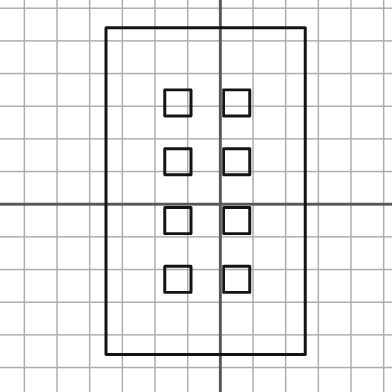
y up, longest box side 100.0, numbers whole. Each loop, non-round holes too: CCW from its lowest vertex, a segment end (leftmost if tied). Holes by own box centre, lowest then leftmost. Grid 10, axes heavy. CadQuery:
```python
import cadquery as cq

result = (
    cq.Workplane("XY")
    .moveTo(-35.0, -46.0)
    .lineTo(26.0, -46.0)
    .lineTo(26.0, 54.0)
    .lineTo(-35.0, 54.0)
    .close()
    .moveTo(-17.0, -27.0)
    .lineTo(-9.0, -27.0)
    .lineTo(-9.0, -19.0)
    .lineTo(-17.0, -19.0)
    .close()
    .moveTo(1.0, -27.0)
    .lineTo(9.0, -27.0)
    .lineTo(9.0, -19.0)
    .lineTo(1.0, -19.0)
    .close()
    .moveTo(-17.0, -9.0)
    .lineTo(-9.0, -9.0)
    .lineTo(-9.0, -1.0)
    .lineTo(-17.0, -1.0)
    .close()
    .moveTo(1.0, -9.0)
    .lineTo(9.0, -9.0)
    .lineTo(9.0, -1.0)
    .lineTo(1.0, -1.0)
    .close()
    .moveTo(-17.0, 9.0)
    .lineTo(-9.0, 9.0)
    .lineTo(-9.0, 17.0)
    .lineTo(-17.0, 17.0)
    .close()
    .moveTo(1.0, 9.0)
    .lineTo(9.0, 9.0)
    .lineTo(9.0, 17.0)
    .lineTo(1.0, 17.0)
    .close()
    .moveTo(-17.0, 27.0)
    .lineTo(-9.0, 27.0)
    .lineTo(-9.0, 35.0)
    .lineTo(-17.0, 35.0)
    .close()
    .moveTo(1.0, 27.0)
    .lineTo(9.0, 27.0)
    .lineTo(9.0, 35.0)
    .lineTo(1.0, 35.0)
    .close()
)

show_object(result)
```